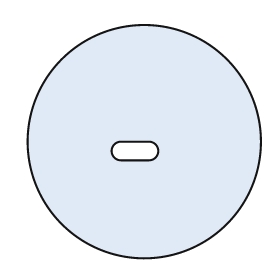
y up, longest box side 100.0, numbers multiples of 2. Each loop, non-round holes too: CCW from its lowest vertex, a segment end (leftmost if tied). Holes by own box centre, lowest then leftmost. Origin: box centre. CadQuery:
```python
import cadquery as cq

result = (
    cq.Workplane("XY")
    .moveTo(0.0, 0.0)
    .circle(50.0)
    .moveTo(-10.0, -8.0)
    .lineTo(2.0, -8.0)
    .threePointArc((6.0, -4.0), (2.0, 0.0))
    .lineTo(-10.0, 0.0)
    .threePointArc((-14.0, -4.0), (-10.0, -8.0))
    .close()
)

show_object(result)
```